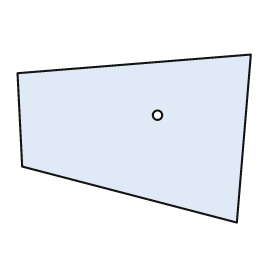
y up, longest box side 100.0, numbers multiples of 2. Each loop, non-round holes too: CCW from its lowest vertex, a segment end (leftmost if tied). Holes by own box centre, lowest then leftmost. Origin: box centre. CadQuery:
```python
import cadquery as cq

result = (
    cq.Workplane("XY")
    .moveTo(44.0, -36.0)
    .lineTo(50.0, 36.0)
    .lineTo(-50.0, 28.0)
    .lineTo(-48.0, -12.0)
    .close()
    .moveTo(10.0, 10.0)
    .circle(2.0)
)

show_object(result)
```